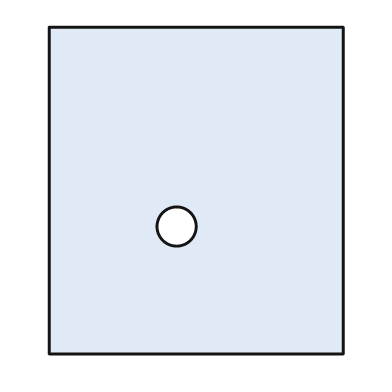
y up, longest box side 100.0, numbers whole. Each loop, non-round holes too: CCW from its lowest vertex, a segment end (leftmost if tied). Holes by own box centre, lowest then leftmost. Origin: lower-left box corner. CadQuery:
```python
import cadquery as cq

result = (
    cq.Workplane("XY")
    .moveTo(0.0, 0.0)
    .lineTo(90.0, 0.0)
    .lineTo(90.0, 100.0)
    .lineTo(0.0, 100.0)
    .close()
    .moveTo(39.0, 39.0)
    .circle(6.0)
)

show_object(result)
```